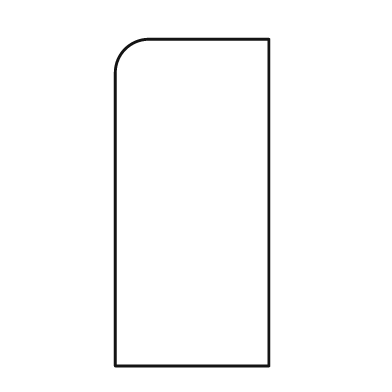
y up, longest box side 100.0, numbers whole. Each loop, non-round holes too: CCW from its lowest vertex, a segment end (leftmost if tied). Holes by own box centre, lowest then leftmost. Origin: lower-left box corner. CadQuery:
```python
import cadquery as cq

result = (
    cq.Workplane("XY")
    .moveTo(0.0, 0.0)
    .lineTo(47.0, 0.0)
    .lineTo(47.0, 100.0)
    .lineTo(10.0, 100.0)
    .threePointArc((3.0, 97.0), (0.0, 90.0))
    .close()
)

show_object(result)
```